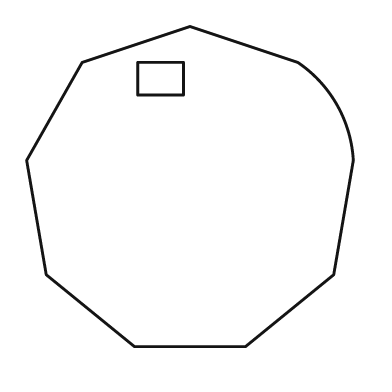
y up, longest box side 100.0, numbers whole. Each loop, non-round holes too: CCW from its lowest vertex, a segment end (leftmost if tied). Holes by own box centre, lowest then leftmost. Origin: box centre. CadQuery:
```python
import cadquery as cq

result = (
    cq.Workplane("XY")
    .moveTo(-17.0, -49.0)
    .lineTo(17.0, -49.0)
    .lineTo(44.0, -27.0)
    .lineTo(50.0, 8.0)
    .threePointArc((45.0, 25.0), (33.0, 38.0))
    .lineTo(0.0, 49.0)
    .lineTo(-33.0, 38.0)
    .lineTo(-50.0, 8.0)
    .lineTo(-44.0, -27.0)
    .close()
    .moveTo(-16.0, 28.0)
    .lineTo(-2.0, 28.0)
    .lineTo(-2.0, 38.0)
    .lineTo(-16.0, 38.0)
    .close()
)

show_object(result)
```